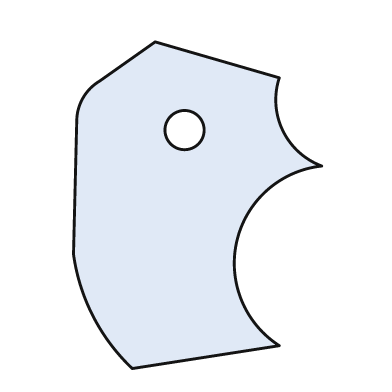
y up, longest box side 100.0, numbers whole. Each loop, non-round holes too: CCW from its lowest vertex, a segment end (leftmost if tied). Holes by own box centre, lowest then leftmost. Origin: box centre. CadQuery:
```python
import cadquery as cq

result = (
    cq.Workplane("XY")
    .moveTo(-20.0, -50.0)
    .lineTo(25.0, -43.0)
    .threePointArc((12.0, -11.0), (38.0, 12.0))
    .threePointArc((26.0, 23.0), (25.0, 39.0))
    .lineTo(-13.0, 50.0)
    .lineTo(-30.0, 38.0)
    .threePointArc((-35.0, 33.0), (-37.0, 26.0))
    .lineTo(-38.0, -15.0)
    .threePointArc((-32.0, -34.0), (-20.0, -50.0))
    .close()
    .moveTo(-4.0, 23.0)
    .circle(6.0)
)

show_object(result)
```